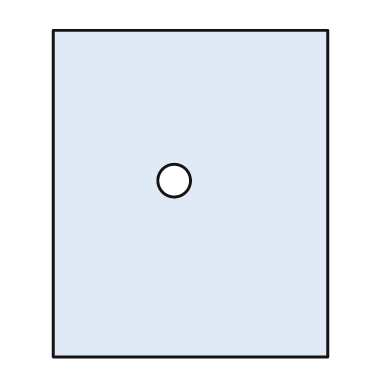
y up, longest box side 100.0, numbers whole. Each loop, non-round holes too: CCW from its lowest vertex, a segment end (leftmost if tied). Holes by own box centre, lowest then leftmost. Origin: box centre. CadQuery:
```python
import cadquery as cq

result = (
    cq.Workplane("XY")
    .moveTo(-42.0, -50.0)
    .lineTo(42.0, -50.0)
    .lineTo(42.0, 50.0)
    .lineTo(-42.0, 50.0)
    .close()
    .moveTo(-5.0, 4.0)
    .circle(5.0)
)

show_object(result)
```